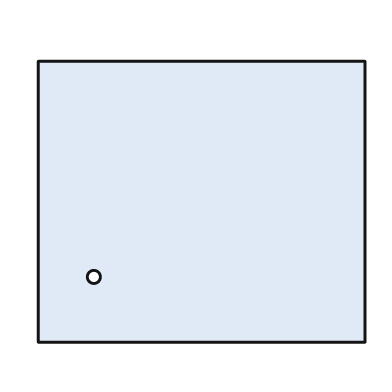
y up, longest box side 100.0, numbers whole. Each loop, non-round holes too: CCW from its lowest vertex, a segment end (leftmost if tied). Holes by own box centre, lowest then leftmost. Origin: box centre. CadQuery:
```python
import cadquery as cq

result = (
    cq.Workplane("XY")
    .moveTo(-50.0, -43.0)
    .lineTo(50.0, -43.0)
    .lineTo(50.0, 43.0)
    .lineTo(-50.0, 43.0)
    .close()
    .moveTo(-33.0, -23.0)
    .circle(2.0)
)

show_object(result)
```